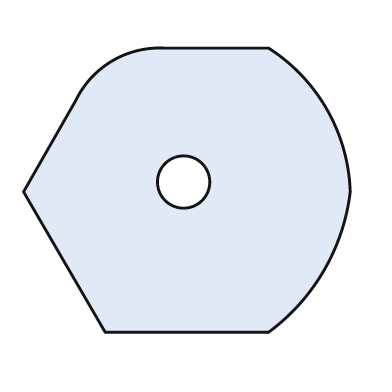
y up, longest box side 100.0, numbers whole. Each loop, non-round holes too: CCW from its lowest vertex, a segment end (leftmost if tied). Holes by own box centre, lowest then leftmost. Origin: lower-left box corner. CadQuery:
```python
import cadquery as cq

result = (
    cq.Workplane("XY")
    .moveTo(25.0, 0.0)
    .lineTo(75.0, 0.0)
    .threePointArc((92.0, 19.0), (100.0, 43.0))
    .threePointArc((93.0, 68.0), (75.0, 87.0))
    .lineTo(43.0, 87.0)
    .threePointArc((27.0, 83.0), (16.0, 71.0))
    .lineTo(0.0, 43.0)
    .close()
    .moveTo(49.0, 46.0)
    .circle(8.0)
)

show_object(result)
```